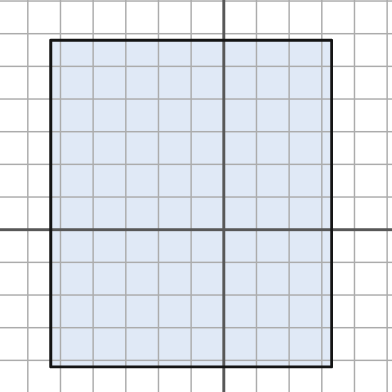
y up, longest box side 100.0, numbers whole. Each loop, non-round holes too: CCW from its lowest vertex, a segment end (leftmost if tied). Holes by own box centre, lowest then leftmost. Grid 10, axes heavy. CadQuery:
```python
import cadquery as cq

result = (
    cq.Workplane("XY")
    .moveTo(-53.0, -42.0)
    .lineTo(33.0, -42.0)
    .lineTo(33.0, 58.0)
    .lineTo(-53.0, 58.0)
    .close()
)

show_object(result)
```